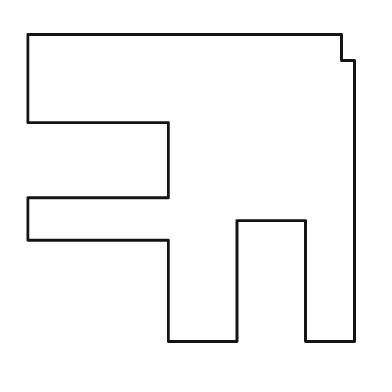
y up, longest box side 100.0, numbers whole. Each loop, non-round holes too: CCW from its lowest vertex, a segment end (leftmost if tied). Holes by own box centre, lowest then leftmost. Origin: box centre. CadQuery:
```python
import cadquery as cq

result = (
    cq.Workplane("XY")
    .moveTo(-7.0, -47.0)
    .lineTo(14.0, -47.0)
    .lineTo(14.0, -10.0)
    .lineTo(35.0, -10.0)
    .lineTo(35.0, -47.0)
    .lineTo(50.0, -47.0)
    .lineTo(50.0, 39.0)
    .lineTo(46.0, 39.0)
    .lineTo(46.0, 47.0)
    .lineTo(-50.0, 47.0)
    .lineTo(-50.0, 20.0)
    .lineTo(-7.0, 20.0)
    .lineTo(-7.0, -3.0)
    .lineTo(-50.0, -3.0)
    .lineTo(-50.0, -16.0)
    .lineTo(-7.0, -16.0)
    .close()
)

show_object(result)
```